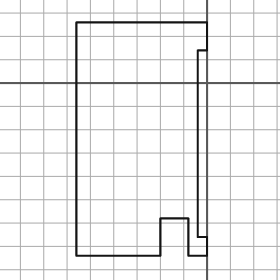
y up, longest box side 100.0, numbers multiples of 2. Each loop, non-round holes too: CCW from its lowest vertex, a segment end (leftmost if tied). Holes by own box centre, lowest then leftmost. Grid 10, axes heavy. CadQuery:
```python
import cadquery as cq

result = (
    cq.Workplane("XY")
    .moveTo(-56.0, -74.0)
    .lineTo(-20.0, -74.0)
    .lineTo(-20.0, -58.0)
    .lineTo(-8.0, -58.0)
    .lineTo(-8.0, -74.0)
    .lineTo(0.0, -74.0)
    .lineTo(0.0, -66.0)
    .lineTo(-4.0, -66.0)
    .lineTo(-4.0, 14.0)
    .lineTo(0.0, 14.0)
    .lineTo(0.0, 26.0)
    .lineTo(-56.0, 26.0)
    .close()
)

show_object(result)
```